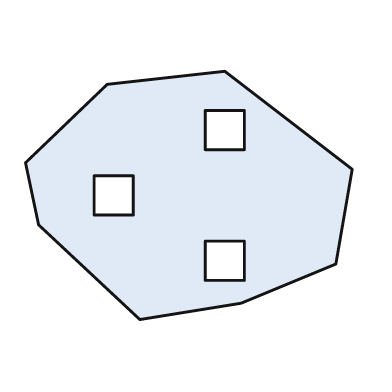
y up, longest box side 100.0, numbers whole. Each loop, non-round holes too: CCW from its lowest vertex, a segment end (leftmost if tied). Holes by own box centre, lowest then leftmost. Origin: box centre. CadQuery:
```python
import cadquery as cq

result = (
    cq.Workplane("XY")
    .moveTo(-15.0, -38.0)
    .lineTo(16.0, -33.0)
    .lineTo(45.0, -21.0)
    .lineTo(50.0, 8.0)
    .lineTo(11.0, 38.0)
    .lineTo(-25.0, 34.0)
    .lineTo(-50.0, 10.0)
    .lineTo(-46.0, -9.0)
    .close()
    .moveTo(5.0, -26.0)
    .lineTo(17.0, -26.0)
    .lineTo(17.0, -14.0)
    .lineTo(5.0, -14.0)
    .close()
    .moveTo(-29.0, -6.0)
    .lineTo(-17.0, -6.0)
    .lineTo(-17.0, 6.0)
    .lineTo(-29.0, 6.0)
    .close()
    .moveTo(5.0, 14.0)
    .lineTo(17.0, 14.0)
    .lineTo(17.0, 26.0)
    .lineTo(5.0, 26.0)
    .close()
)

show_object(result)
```